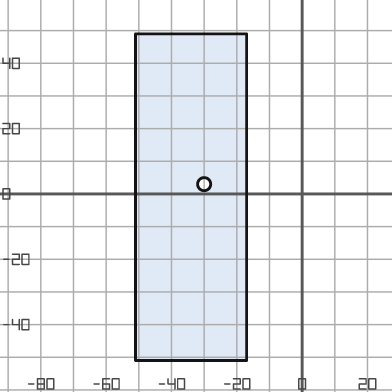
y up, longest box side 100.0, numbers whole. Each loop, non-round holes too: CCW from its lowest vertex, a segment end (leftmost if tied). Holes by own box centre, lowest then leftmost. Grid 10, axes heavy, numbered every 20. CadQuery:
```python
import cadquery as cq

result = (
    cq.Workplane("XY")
    .moveTo(-51.0, -51.0)
    .lineTo(-17.0, -51.0)
    .lineTo(-17.0, 49.0)
    .lineTo(-51.0, 49.0)
    .close()
    .moveTo(-30.0, 3.0)
    .circle(2.0)
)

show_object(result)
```